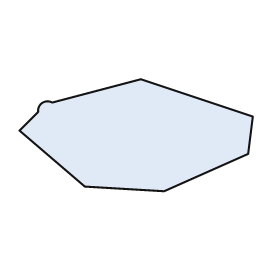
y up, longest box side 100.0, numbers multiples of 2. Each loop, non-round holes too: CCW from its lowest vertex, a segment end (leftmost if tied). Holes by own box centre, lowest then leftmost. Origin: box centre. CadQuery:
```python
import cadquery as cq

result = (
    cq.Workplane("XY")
    .moveTo(12.0, -24.0)
    .lineTo(48.0, -8.0)
    .lineTo(50.0, 8.0)
    .lineTo(2.0, 24.0)
    .lineTo(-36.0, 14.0)
    .threePointArc((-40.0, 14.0), (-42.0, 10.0))
    .lineTo(-50.0, 2.0)
    .lineTo(-22.0, -22.0)
    .close()
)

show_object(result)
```